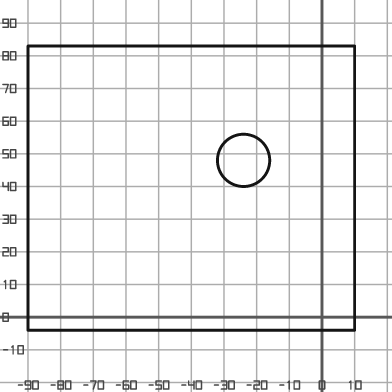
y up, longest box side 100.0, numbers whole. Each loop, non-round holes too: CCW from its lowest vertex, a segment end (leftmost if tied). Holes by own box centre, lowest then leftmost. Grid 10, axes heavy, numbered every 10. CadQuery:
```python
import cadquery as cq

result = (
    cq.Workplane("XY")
    .moveTo(-90.0, -4.0)
    .lineTo(10.0, -4.0)
    .lineTo(10.0, 83.0)
    .lineTo(-90.0, 83.0)
    .close()
    .moveTo(-24.0, 48.0)
    .circle(8.0)
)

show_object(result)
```